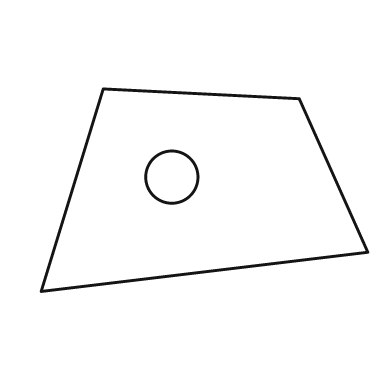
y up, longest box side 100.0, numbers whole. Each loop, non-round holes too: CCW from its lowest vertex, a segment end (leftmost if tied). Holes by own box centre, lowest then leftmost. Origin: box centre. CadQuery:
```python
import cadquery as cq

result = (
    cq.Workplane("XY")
    .moveTo(-50.0, -31.0)
    .lineTo(50.0, -19.0)
    .lineTo(29.0, 28.0)
    .lineTo(-31.0, 31.0)
    .close()
    .moveTo(-10.0, 4.0)
    .circle(8.0)
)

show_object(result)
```